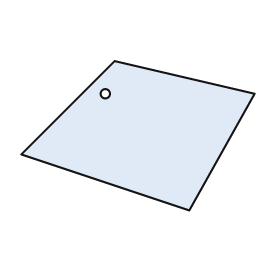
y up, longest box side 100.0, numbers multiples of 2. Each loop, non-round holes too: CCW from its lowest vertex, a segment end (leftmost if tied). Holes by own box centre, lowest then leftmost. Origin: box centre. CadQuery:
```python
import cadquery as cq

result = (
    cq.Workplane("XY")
    .moveTo(22.0, -32.0)
    .lineTo(50.0, 18.0)
    .lineTo(-10.0, 32.0)
    .lineTo(-50.0, -8.0)
    .close()
    .moveTo(-14.0, 18.0)
    .circle(2.0)
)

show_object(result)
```